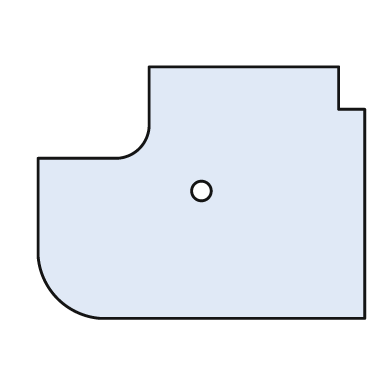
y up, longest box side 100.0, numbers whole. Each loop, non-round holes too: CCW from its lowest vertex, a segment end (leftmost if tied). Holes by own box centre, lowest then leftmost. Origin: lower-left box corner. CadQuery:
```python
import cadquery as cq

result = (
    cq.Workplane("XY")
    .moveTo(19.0, 0.0)
    .lineTo(100.0, 0.0)
    .lineTo(100.0, 64.0)
    .lineTo(92.0, 64.0)
    .lineTo(92.0, 77.0)
    .lineTo(34.0, 77.0)
    .lineTo(34.0, 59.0)
    .threePointArc((31.0, 52.0), (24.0, 49.0))
    .lineTo(0.0, 49.0)
    .lineTo(0.0, 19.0)
    .threePointArc((6.0, 6.0), (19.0, 0.0))
    .close()
    .moveTo(50.0, 39.0)
    .circle(3.0)
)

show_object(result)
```